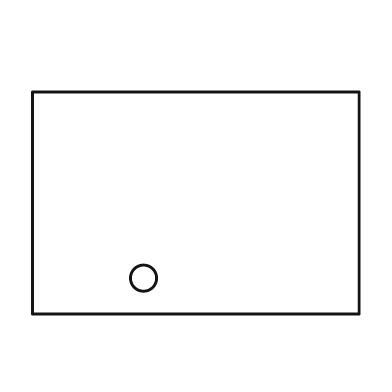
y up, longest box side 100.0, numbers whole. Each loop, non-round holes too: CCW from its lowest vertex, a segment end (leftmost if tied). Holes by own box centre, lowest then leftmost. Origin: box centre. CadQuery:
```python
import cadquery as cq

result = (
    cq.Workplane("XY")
    .moveTo(-50.0, -34.0)
    .lineTo(50.0, -34.0)
    .lineTo(50.0, 34.0)
    .lineTo(-50.0, 34.0)
    .close()
    .moveTo(-16.0, -23.0)
    .circle(4.0)
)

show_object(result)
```